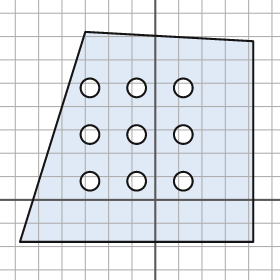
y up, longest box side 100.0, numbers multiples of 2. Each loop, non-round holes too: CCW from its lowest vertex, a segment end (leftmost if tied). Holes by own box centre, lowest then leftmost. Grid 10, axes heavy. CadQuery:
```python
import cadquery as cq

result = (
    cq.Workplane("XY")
    .moveTo(-58.0, -18.0)
    .lineTo(42.0, -18.0)
    .lineTo(42.0, 68.0)
    .lineTo(-30.0, 72.0)
    .close()
    .moveTo(-28.0, 8.0)
    .circle(4.0)
    .moveTo(-8.0, 8.0)
    .circle(4.0)
    .moveTo(12.0, 8.0)
    .circle(4.0)
    .moveTo(-28.0, 28.0)
    .circle(4.0)
    .moveTo(-8.0, 28.0)
    .circle(4.0)
    .moveTo(12.0, 28.0)
    .circle(4.0)
    .moveTo(-28.0, 48.0)
    .circle(4.0)
    .moveTo(-8.0, 48.0)
    .circle(4.0)
    .moveTo(12.0, 48.0)
    .circle(4.0)
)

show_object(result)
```